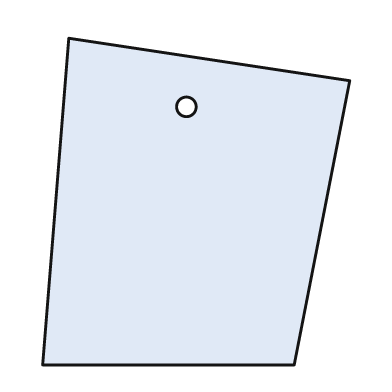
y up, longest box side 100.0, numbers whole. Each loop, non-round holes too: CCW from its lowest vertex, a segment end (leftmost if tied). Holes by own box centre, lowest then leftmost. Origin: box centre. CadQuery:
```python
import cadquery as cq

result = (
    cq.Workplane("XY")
    .moveTo(-47.0, -50.0)
    .lineTo(30.0, -50.0)
    .lineTo(47.0, 37.0)
    .lineTo(-39.0, 50.0)
    .close()
    .moveTo(-3.0, 29.0)
    .circle(3.0)
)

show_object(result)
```